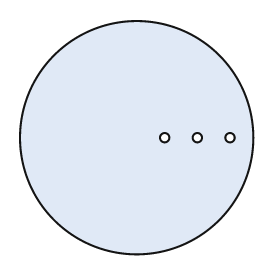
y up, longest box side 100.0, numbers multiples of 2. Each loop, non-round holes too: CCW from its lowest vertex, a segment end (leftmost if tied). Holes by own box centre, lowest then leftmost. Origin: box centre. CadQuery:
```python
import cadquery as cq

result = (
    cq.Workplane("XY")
    .moveTo(0.0, 0.0)
    .circle(50.0)
    .moveTo(12.0, 0.0)
    .circle(2.0)
    .moveTo(26.0, 0.0)
    .circle(2.0)
    .moveTo(40.0, 0.0)
    .circle(2.0)
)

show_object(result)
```